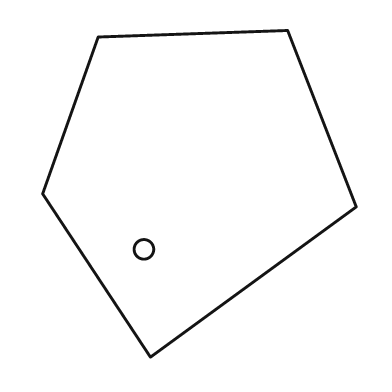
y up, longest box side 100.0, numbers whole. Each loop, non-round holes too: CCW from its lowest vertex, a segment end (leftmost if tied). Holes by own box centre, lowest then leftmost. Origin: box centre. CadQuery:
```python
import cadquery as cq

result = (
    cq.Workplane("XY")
    .moveTo(-15.0, -50.0)
    .lineTo(48.0, -4.0)
    .lineTo(27.0, 50.0)
    .lineTo(-31.0, 48.0)
    .lineTo(-48.0, 0.0)
    .close()
    .moveTo(-17.0, -17.0)
    .circle(3.0)
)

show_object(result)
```